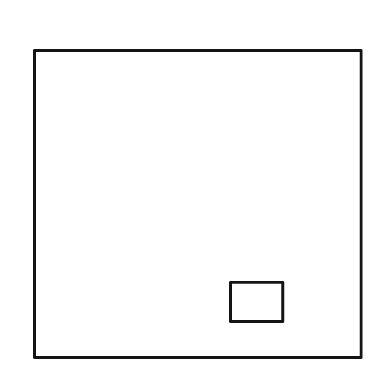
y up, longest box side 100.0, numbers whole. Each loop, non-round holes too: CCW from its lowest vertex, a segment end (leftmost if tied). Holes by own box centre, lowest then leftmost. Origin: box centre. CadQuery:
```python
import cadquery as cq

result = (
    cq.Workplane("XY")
    .moveTo(-50.0, -47.0)
    .lineTo(50.0, -47.0)
    .lineTo(50.0, 47.0)
    .lineTo(-50.0, 47.0)
    .close()
    .moveTo(10.0, -36.0)
    .lineTo(26.0, -36.0)
    .lineTo(26.0, -24.0)
    .lineTo(10.0, -24.0)
    .close()
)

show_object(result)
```